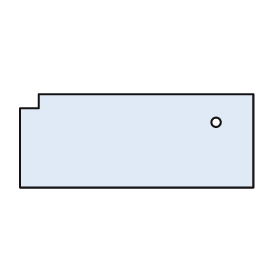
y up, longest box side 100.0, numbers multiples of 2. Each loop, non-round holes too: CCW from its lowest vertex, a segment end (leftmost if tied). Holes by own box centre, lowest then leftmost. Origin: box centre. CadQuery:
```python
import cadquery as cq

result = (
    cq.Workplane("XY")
    .moveTo(-50.0, -20.0)
    .lineTo(50.0, -20.0)
    .lineTo(50.0, 20.0)
    .lineTo(-42.0, 20.0)
    .lineTo(-42.0, 14.0)
    .lineTo(-50.0, 14.0)
    .close()
    .moveTo(34.0, 8.0)
    .circle(2.0)
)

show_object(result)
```